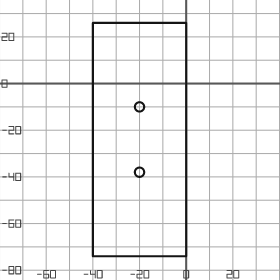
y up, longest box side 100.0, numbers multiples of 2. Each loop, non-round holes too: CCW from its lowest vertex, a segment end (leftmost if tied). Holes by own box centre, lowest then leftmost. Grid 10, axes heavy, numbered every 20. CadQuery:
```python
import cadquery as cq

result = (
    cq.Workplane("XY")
    .moveTo(-40.0, -74.0)
    .lineTo(0.0, -74.0)
    .lineTo(0.0, 26.0)
    .lineTo(-40.0, 26.0)
    .close()
    .moveTo(-20.0, -38.0)
    .circle(2.0)
    .moveTo(-20.0, -10.0)
    .circle(2.0)
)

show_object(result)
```